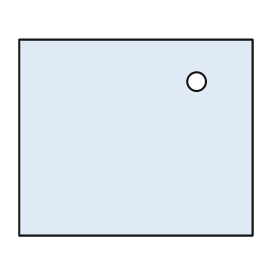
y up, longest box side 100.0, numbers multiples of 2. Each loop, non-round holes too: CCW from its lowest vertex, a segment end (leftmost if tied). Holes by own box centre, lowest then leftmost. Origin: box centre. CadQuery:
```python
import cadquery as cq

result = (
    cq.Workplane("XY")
    .moveTo(-50.0, -42.0)
    .lineTo(50.0, -42.0)
    .lineTo(50.0, 42.0)
    .lineTo(-50.0, 42.0)
    .close()
    .moveTo(26.0, 24.0)
    .circle(4.0)
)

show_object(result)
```